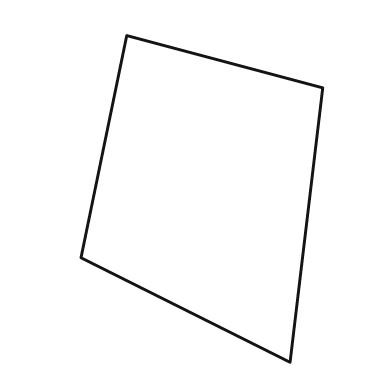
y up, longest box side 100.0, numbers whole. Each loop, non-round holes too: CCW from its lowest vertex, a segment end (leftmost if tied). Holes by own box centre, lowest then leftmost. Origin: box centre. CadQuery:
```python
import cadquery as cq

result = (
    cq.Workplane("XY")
    .moveTo(27.0, -50.0)
    .lineTo(37.0, 34.0)
    .lineTo(-23.0, 50.0)
    .lineTo(-37.0, -18.0)
    .close()
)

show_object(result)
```